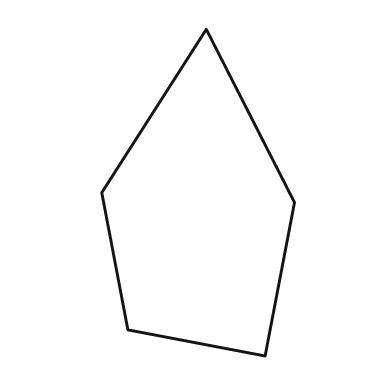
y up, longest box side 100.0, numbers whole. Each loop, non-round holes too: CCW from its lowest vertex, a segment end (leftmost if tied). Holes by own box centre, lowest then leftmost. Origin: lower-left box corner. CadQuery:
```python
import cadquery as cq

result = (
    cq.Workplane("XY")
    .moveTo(50.0, 0.0)
    .lineTo(59.0, 47.0)
    .lineTo(32.0, 100.0)
    .lineTo(0.0, 50.0)
    .lineTo(8.0, 8.0)
    .close()
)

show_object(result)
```